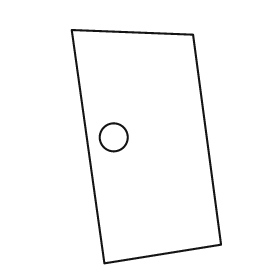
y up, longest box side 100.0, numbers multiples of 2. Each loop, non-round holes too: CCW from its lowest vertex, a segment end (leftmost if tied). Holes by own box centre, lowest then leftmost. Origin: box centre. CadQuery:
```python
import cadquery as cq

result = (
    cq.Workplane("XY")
    .moveTo(-18.0, -50.0)
    .lineTo(32.0, -42.0)
    .lineTo(20.0, 48.0)
    .lineTo(-32.0, 50.0)
    .close()
    .moveTo(-14.0, 4.0)
    .circle(6.0)
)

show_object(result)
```